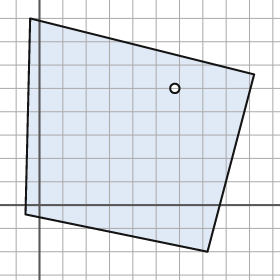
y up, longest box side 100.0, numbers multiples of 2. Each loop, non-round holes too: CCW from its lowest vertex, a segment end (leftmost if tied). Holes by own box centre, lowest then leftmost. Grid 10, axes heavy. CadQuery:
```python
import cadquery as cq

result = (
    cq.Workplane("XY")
    .moveTo(72.0, -20.0)
    .lineTo(92.0, 56.0)
    .lineTo(-4.0, 80.0)
    .lineTo(-6.0, -4.0)
    .close()
    .moveTo(58.0, 50.0)
    .circle(2.0)
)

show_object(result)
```